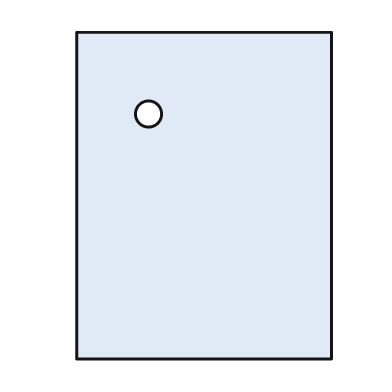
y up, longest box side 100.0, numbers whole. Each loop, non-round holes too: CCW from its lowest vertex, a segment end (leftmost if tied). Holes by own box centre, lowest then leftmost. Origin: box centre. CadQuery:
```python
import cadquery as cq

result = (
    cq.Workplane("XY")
    .moveTo(-39.0, -50.0)
    .lineTo(39.0, -50.0)
    .lineTo(39.0, 50.0)
    .lineTo(-39.0, 50.0)
    .close()
    .moveTo(-17.0, 25.0)
    .circle(4.0)
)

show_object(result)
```